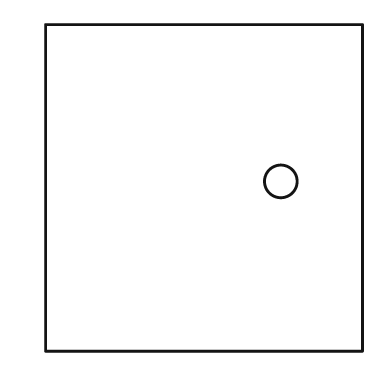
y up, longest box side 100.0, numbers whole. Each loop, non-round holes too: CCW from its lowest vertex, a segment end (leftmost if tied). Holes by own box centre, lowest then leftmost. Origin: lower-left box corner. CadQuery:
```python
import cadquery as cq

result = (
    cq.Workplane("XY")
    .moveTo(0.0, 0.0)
    .lineTo(97.0, 0.0)
    .lineTo(97.0, 100.0)
    .lineTo(0.0, 100.0)
    .close()
    .moveTo(72.0, 52.0)
    .circle(5.0)
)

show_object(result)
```